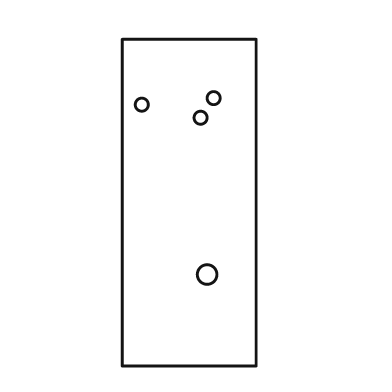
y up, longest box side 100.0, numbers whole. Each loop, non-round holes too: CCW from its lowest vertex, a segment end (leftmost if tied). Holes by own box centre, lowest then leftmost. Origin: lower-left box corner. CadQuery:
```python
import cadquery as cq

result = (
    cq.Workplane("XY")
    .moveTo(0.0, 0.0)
    .lineTo(41.0, 0.0)
    .lineTo(41.0, 100.0)
    .lineTo(0.0, 100.0)
    .close()
    .moveTo(26.0, 28.0)
    .circle(3.0)
    .moveTo(24.0, 76.0)
    .circle(2.0)
    .moveTo(6.0, 80.0)
    .circle(2.0)
    .moveTo(28.0, 82.0)
    .circle(2.0)
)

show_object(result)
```